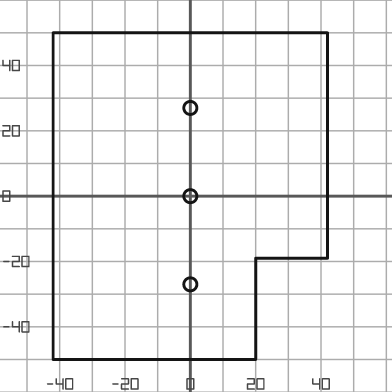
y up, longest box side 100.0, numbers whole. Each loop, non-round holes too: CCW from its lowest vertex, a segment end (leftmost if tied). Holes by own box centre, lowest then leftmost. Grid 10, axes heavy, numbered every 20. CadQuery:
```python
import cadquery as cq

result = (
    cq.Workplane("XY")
    .moveTo(-42.0, -50.0)
    .lineTo(20.0, -50.0)
    .lineTo(20.0, -19.0)
    .lineTo(42.0, -19.0)
    .lineTo(42.0, 50.0)
    .lineTo(-42.0, 50.0)
    .close()
    .moveTo(0.0, -27.0)
    .circle(2.0)
    .moveTo(0.0, 0.0)
    .circle(2.0)
    .moveTo(0.0, 27.0)
    .circle(2.0)
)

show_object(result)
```